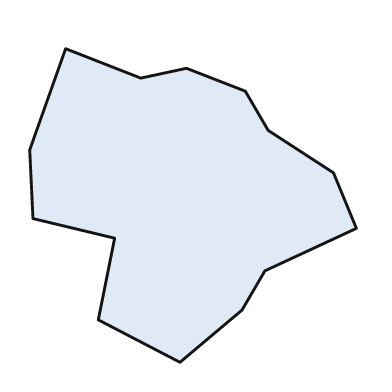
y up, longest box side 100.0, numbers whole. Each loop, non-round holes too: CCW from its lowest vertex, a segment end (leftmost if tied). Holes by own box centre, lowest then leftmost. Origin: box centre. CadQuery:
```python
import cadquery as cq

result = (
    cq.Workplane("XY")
    .moveTo(-4.0, -48.0)
    .lineTo(15.0, -32.0)
    .lineTo(22.0, -20.0)
    .lineTo(50.0, -7.0)
    .lineTo(43.0, 10.0)
    .lineTo(23.0, 23.0)
    .lineTo(16.0, 35.0)
    .lineTo(-2.0, 42.0)
    .lineTo(-16.0, 39.0)
    .lineTo(-39.0, 48.0)
    .lineTo(-50.0, 17.0)
    .lineTo(-49.0, -4.0)
    .lineTo(-24.0, -10.0)
    .lineTo(-29.0, -35.0)
    .close()
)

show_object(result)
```